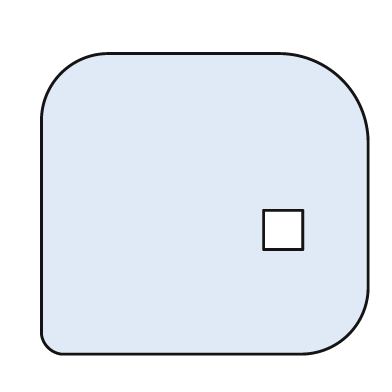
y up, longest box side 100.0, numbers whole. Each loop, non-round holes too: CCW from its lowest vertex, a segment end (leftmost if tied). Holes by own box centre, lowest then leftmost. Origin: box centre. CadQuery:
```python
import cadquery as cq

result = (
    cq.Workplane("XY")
    .moveTo(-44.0, -46.0)
    .lineTo(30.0, -46.0)
    .threePointArc((44.0, -40.0), (50.0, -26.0))
    .lineTo(50.0, 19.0)
    .threePointArc((42.0, 38.0), (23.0, 46.0))
    .lineTo(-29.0, 46.0)
    .threePointArc((-44.0, 40.0), (-50.0, 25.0))
    .lineTo(-50.0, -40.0)
    .threePointArc((-48.0, -44.0), (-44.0, -46.0))
    .close()
    .moveTo(18.0, -14.0)
    .lineTo(30.0, -14.0)
    .lineTo(30.0, -2.0)
    .lineTo(18.0, -2.0)
    .close()
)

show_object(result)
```